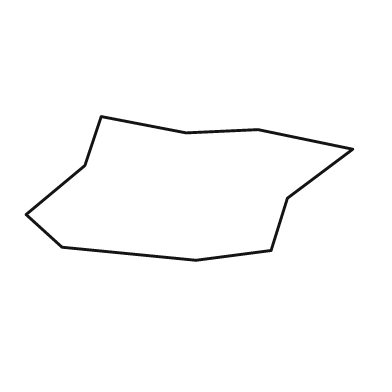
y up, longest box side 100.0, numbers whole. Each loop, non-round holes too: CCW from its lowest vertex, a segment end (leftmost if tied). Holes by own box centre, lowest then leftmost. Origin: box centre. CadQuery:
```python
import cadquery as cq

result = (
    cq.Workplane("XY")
    .moveTo(2.0, -22.0)
    .lineTo(25.0, -19.0)
    .lineTo(30.0, -3.0)
    .lineTo(50.0, 12.0)
    .lineTo(21.0, 18.0)
    .lineTo(-1.0, 17.0)
    .lineTo(-27.0, 22.0)
    .lineTo(-32.0, 7.0)
    .lineTo(-50.0, -8.0)
    .lineTo(-39.0, -18.0)
    .close()
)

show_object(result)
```